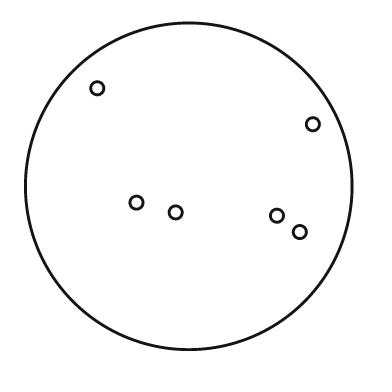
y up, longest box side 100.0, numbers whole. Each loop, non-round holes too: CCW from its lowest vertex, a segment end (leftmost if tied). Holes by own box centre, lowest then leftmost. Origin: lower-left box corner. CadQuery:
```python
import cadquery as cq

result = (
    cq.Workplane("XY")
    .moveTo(50.0, 50.0)
    .circle(50.0)
    .moveTo(84.0, 36.0)
    .circle(2.0)
    .moveTo(77.0, 41.0)
    .circle(2.0)
    .moveTo(46.0, 42.0)
    .circle(2.0)
    .moveTo(34.0, 45.0)
    .circle(2.0)
    .moveTo(88.0, 69.0)
    .circle(2.0)
    .moveTo(22.0, 80.0)
    .circle(2.0)
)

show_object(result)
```